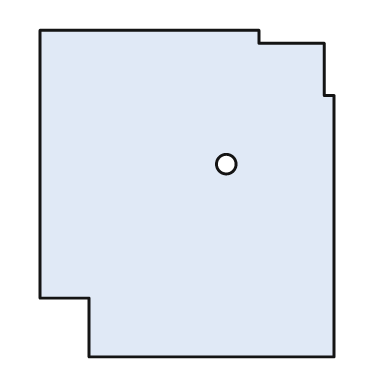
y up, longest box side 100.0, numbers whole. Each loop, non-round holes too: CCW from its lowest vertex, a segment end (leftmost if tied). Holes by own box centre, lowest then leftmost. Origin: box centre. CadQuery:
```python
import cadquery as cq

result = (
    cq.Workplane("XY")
    .moveTo(-30.0, -50.0)
    .lineTo(45.0, -50.0)
    .lineTo(45.0, 30.0)
    .lineTo(42.0, 30.0)
    .lineTo(42.0, 46.0)
    .lineTo(22.0, 46.0)
    .lineTo(22.0, 50.0)
    .lineTo(-45.0, 50.0)
    .lineTo(-45.0, -32.0)
    .lineTo(-30.0, -32.0)
    .close()
    .moveTo(12.0, 9.0)
    .circle(3.0)
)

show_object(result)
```